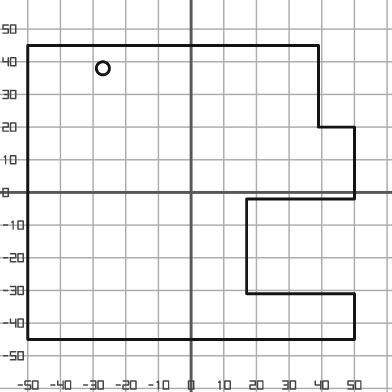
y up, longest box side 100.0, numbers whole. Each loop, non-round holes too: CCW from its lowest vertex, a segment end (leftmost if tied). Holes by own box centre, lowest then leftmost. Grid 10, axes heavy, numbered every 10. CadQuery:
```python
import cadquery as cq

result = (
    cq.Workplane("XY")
    .moveTo(-50.0, -45.0)
    .lineTo(50.0, -45.0)
    .lineTo(50.0, -31.0)
    .lineTo(17.0, -31.0)
    .lineTo(17.0, -2.0)
    .lineTo(50.0, -2.0)
    .lineTo(50.0, 20.0)
    .lineTo(39.0, 20.0)
    .lineTo(39.0, 45.0)
    .lineTo(-50.0, 45.0)
    .close()
    .moveTo(-27.0, 38.0)
    .circle(2.0)
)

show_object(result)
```